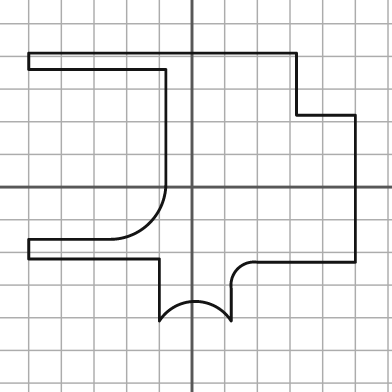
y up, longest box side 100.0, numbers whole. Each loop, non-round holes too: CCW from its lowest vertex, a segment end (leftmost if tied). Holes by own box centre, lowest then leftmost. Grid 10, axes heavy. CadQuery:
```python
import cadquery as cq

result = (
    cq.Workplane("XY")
    .moveTo(-10.0, -41.0)
    .threePointArc((1.0, -35.0), (12.0, -41.0))
    .lineTo(12.0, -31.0)
    .threePointArc((14.0, -25.0), (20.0, -23.0))
    .lineTo(50.0, -23.0)
    .lineTo(50.0, 22.0)
    .lineTo(32.0, 22.0)
    .lineTo(32.0, 41.0)
    .lineTo(-50.0, 41.0)
    .lineTo(-50.0, 36.0)
    .lineTo(-8.0, 36.0)
    .lineTo(-8.0, 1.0)
    .threePointArc((-13.0, -11.0), (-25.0, -16.0))
    .lineTo(-50.0, -16.0)
    .lineTo(-50.0, -22.0)
    .lineTo(-10.0, -22.0)
    .close()
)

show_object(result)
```